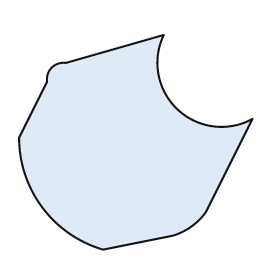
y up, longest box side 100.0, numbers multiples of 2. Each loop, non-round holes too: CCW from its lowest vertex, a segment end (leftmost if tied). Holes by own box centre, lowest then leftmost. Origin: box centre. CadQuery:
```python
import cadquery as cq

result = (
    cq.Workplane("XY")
    .moveTo(-14.0, -46.0)
    .lineTo(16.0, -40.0)
    .threePointArc((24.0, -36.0), (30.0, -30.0))
    .lineTo(50.0, 10.0)
    .threePointArc((18.0, 14.0), (12.0, 46.0))
    .lineTo(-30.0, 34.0)
    .threePointArc((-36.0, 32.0), (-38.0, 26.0))
    .lineTo(-50.0, 2.0)
    .threePointArc((-40.0, -28.0), (-14.0, -46.0))
    .close()
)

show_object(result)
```